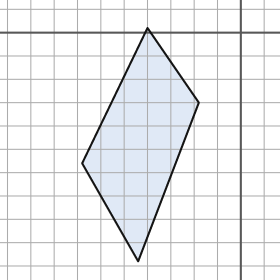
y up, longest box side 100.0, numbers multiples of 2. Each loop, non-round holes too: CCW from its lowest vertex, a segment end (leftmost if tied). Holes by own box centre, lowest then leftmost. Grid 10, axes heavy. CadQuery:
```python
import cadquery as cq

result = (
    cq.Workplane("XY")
    .moveTo(-44.0, -98.0)
    .lineTo(-18.0, -30.0)
    .lineTo(-40.0, 2.0)
    .lineTo(-68.0, -56.0)
    .close()
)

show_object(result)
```